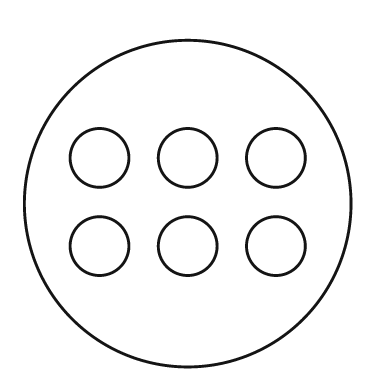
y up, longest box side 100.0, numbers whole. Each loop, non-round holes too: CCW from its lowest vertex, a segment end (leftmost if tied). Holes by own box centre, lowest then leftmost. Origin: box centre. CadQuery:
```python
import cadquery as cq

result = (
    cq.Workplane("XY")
    .moveTo(0.0, 0.0)
    .circle(50.0)
    .moveTo(-27.0, -13.0)
    .circle(9.0)
    .moveTo(0.0, -13.0)
    .circle(9.0)
    .moveTo(27.0, -13.0)
    .circle(9.0)
    .moveTo(-27.0, 14.0)
    .circle(9.0)
    .moveTo(0.0, 14.0)
    .circle(9.0)
    .moveTo(27.0, 14.0)
    .circle(9.0)
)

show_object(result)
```